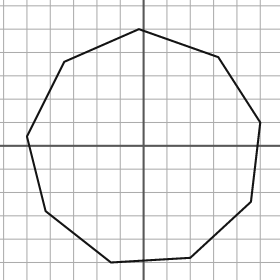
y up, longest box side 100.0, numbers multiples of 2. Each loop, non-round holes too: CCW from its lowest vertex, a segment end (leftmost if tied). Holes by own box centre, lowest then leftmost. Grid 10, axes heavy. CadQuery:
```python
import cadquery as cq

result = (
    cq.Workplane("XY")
    .moveTo(-14.0, -50.0)
    .lineTo(20.0, -48.0)
    .lineTo(46.0, -24.0)
    .lineTo(50.0, 10.0)
    .lineTo(32.0, 38.0)
    .lineTo(-2.0, 50.0)
    .lineTo(-34.0, 36.0)
    .lineTo(-50.0, 4.0)
    .lineTo(-42.0, -28.0)
    .close()
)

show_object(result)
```